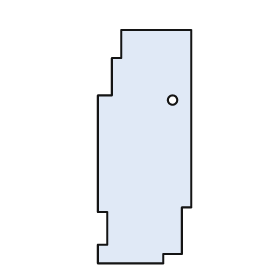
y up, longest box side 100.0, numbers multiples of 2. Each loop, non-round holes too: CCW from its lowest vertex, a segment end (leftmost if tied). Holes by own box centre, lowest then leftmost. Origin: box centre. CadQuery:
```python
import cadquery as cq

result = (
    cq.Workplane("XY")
    .moveTo(-20.0, -50.0)
    .lineTo(8.0, -50.0)
    .lineTo(8.0, -46.0)
    .lineTo(16.0, -46.0)
    .lineTo(16.0, -26.0)
    .lineTo(20.0, -26.0)
    .lineTo(20.0, 50.0)
    .lineTo(-10.0, 50.0)
    .lineTo(-10.0, 38.0)
    .lineTo(-14.0, 38.0)
    .lineTo(-14.0, 22.0)
    .lineTo(-20.0, 22.0)
    .lineTo(-20.0, -28.0)
    .lineTo(-16.0, -28.0)
    .lineTo(-16.0, -42.0)
    .lineTo(-20.0, -42.0)
    .close()
    .moveTo(12.0, 20.0)
    .circle(2.0)
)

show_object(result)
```